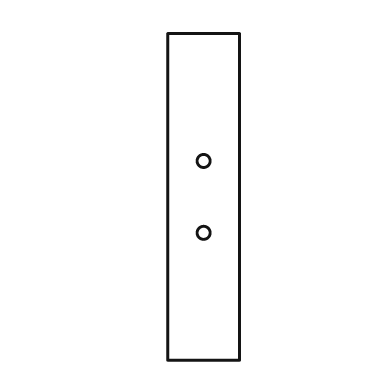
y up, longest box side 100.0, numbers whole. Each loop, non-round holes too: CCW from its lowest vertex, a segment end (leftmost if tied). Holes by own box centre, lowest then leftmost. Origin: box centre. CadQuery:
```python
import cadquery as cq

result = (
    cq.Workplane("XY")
    .moveTo(-11.0, -50.0)
    .lineTo(11.0, -50.0)
    .lineTo(11.0, 50.0)
    .lineTo(-11.0, 50.0)
    .close()
    .moveTo(0.0, -11.0)
    .circle(2.0)
    .moveTo(0.0, 11.0)
    .circle(2.0)
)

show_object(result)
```